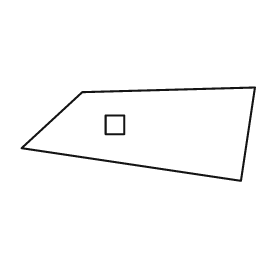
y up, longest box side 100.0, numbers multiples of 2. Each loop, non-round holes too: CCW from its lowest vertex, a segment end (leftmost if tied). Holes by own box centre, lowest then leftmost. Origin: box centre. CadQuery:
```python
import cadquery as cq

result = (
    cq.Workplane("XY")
    .moveTo(44.0, -20.0)
    .lineTo(50.0, 20.0)
    .lineTo(-24.0, 18.0)
    .lineTo(-50.0, -6.0)
    .close()
    .moveTo(-14.0, 0.0)
    .lineTo(-6.0, 0.0)
    .lineTo(-6.0, 8.0)
    .lineTo(-14.0, 8.0)
    .close()
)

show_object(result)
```